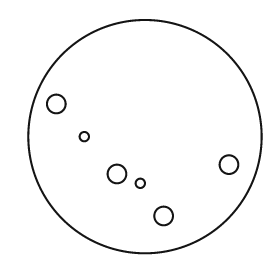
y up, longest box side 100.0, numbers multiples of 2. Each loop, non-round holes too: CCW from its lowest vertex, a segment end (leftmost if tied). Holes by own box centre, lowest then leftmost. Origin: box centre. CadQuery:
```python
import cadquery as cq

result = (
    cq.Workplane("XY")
    .moveTo(0.0, 0.0)
    .circle(50.0)
    .moveTo(8.0, -34.0)
    .circle(4.0)
    .moveTo(-2.0, -20.0)
    .circle(2.0)
    .moveTo(-12.0, -16.0)
    .circle(4.0)
    .moveTo(36.0, -12.0)
    .circle(4.0)
    .moveTo(-26.0, 0.0)
    .circle(2.0)
    .moveTo(-38.0, 14.0)
    .circle(4.0)
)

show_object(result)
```